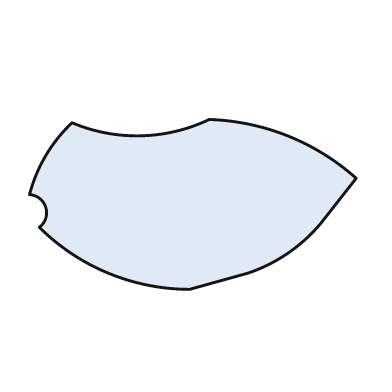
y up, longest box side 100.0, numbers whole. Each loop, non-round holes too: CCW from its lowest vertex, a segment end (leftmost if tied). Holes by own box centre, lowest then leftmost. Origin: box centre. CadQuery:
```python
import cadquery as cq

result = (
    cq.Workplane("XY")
    .moveTo(-1.0, -26.0)
    .lineTo(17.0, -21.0)
    .threePointArc((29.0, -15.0), (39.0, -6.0))
    .lineTo(50.0, 8.0)
    .threePointArc((29.0, 21.0), (5.0, 26.0))
    .threePointArc((-16.0, 21.0), (-37.0, 25.0))
    .threePointArc((-45.0, 15.0), (-50.0, 3.0))
    .threePointArc((-45.0, -1.0), (-47.0, -7.0))
    .threePointArc((-26.0, -21.0), (-1.0, -26.0))
    .close()
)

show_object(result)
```